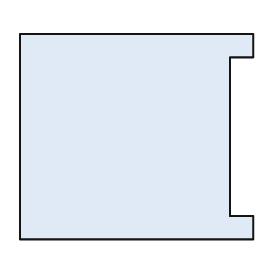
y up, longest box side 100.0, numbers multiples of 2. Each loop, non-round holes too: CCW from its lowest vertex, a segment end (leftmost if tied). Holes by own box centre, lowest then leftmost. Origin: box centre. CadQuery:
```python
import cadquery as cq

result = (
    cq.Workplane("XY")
    .moveTo(-50.0, -44.0)
    .lineTo(50.0, -44.0)
    .lineTo(50.0, -34.0)
    .lineTo(40.0, -34.0)
    .lineTo(40.0, 34.0)
    .lineTo(50.0, 34.0)
    .lineTo(50.0, 44.0)
    .lineTo(-50.0, 44.0)
    .close()
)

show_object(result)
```